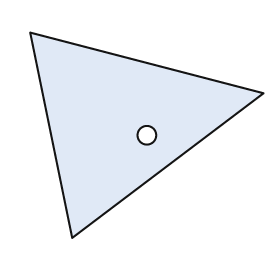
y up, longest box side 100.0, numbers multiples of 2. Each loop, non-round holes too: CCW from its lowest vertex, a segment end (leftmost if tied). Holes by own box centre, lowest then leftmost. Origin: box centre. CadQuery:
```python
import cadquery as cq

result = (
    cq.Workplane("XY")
    .moveTo(-32.0, -44.0)
    .lineTo(50.0, 18.0)
    .lineTo(-50.0, 44.0)
    .close()
    .moveTo(0.0, 0.0)
    .circle(4.0)
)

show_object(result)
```